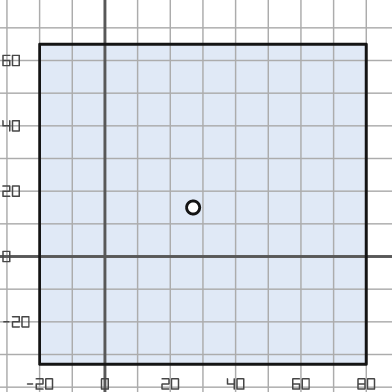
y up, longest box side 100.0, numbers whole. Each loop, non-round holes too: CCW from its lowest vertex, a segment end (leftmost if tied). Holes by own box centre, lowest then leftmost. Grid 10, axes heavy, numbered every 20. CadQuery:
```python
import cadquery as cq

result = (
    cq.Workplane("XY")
    .moveTo(-20.0, -33.0)
    .lineTo(80.0, -33.0)
    .lineTo(80.0, 65.0)
    .lineTo(-20.0, 65.0)
    .close()
    .moveTo(27.0, 15.0)
    .circle(2.0)
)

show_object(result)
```